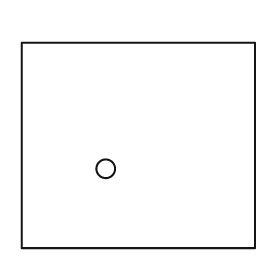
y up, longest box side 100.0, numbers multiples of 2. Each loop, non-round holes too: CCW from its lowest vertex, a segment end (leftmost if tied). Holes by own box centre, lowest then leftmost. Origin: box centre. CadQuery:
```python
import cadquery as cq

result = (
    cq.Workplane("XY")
    .moveTo(-50.0, -44.0)
    .lineTo(50.0, -44.0)
    .lineTo(50.0, 44.0)
    .lineTo(-50.0, 44.0)
    .close()
    .moveTo(-14.0, -10.0)
    .circle(4.0)
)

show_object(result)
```